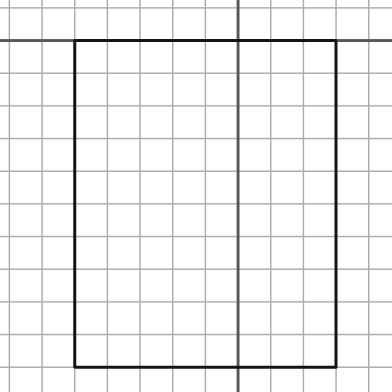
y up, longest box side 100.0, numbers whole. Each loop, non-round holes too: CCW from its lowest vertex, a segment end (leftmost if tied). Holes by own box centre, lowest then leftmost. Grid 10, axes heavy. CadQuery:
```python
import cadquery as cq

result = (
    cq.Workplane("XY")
    .moveTo(-50.0, -100.0)
    .lineTo(30.0, -100.0)
    .lineTo(30.0, 0.0)
    .lineTo(-50.0, 0.0)
    .close()
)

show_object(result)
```